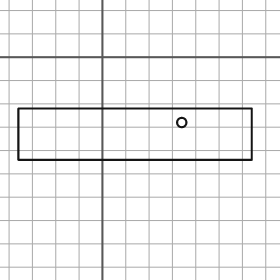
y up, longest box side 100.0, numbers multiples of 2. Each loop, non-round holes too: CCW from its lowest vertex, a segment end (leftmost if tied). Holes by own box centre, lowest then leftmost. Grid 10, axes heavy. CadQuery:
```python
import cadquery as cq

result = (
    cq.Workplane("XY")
    .moveTo(-36.0, -44.0)
    .lineTo(64.0, -44.0)
    .lineTo(64.0, -22.0)
    .lineTo(-36.0, -22.0)
    .close()
    .moveTo(34.0, -28.0)
    .circle(2.0)
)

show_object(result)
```